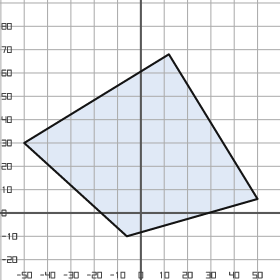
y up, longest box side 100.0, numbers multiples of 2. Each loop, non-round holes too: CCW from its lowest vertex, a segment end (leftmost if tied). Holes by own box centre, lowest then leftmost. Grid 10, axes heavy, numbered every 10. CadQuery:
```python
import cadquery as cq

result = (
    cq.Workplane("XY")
    .moveTo(-6.0, -10.0)
    .lineTo(50.0, 6.0)
    .lineTo(12.0, 68.0)
    .lineTo(-50.0, 30.0)
    .close()
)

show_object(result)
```